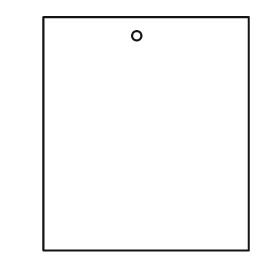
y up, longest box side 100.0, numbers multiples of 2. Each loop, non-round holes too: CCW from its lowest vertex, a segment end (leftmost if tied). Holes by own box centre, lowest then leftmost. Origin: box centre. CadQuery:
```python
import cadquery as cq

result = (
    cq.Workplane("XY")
    .moveTo(-44.0, -50.0)
    .lineTo(44.0, -50.0)
    .lineTo(44.0, 50.0)
    .lineTo(-44.0, 50.0)
    .close()
    .moveTo(-4.0, 42.0)
    .circle(2.0)
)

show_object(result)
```